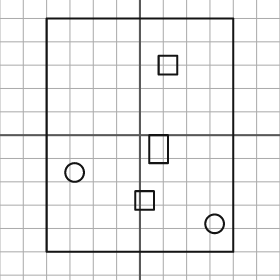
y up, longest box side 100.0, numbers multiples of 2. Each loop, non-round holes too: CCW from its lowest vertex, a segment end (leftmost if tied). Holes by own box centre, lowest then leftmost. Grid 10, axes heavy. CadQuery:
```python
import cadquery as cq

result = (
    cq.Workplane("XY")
    .moveTo(-40.0, -50.0)
    .lineTo(40.0, -50.0)
    .lineTo(40.0, 50.0)
    .lineTo(-40.0, 50.0)
    .close()
    .moveTo(32.0, -38.0)
    .circle(4.0)
    .moveTo(-2.0, -32.0)
    .lineTo(6.0, -32.0)
    .lineTo(6.0, -24.0)
    .lineTo(-2.0, -24.0)
    .close()
    .moveTo(-28.0, -16.0)
    .circle(4.0)
    .moveTo(4.0, -12.0)
    .lineTo(12.0, -12.0)
    .lineTo(12.0, 0.0)
    .lineTo(4.0, 0.0)
    .close()
    .moveTo(8.0, 26.0)
    .lineTo(16.0, 26.0)
    .lineTo(16.0, 34.0)
    .lineTo(8.0, 34.0)
    .close()
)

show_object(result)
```